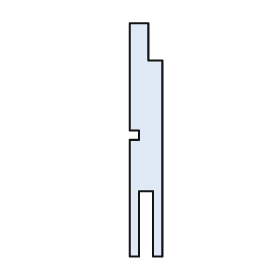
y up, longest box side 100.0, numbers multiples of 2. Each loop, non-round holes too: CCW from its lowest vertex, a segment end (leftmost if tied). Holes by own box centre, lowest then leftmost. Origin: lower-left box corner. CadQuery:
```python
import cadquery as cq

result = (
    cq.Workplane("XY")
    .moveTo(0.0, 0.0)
    .lineTo(4.0, 0.0)
    .lineTo(4.0, 28.0)
    .lineTo(10.0, 28.0)
    .lineTo(10.0, 0.0)
    .lineTo(14.0, 0.0)
    .lineTo(14.0, 84.0)
    .lineTo(8.0, 84.0)
    .lineTo(8.0, 100.0)
    .lineTo(0.0, 100.0)
    .lineTo(0.0, 54.0)
    .lineTo(4.0, 54.0)
    .lineTo(4.0, 50.0)
    .lineTo(0.0, 50.0)
    .close()
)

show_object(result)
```